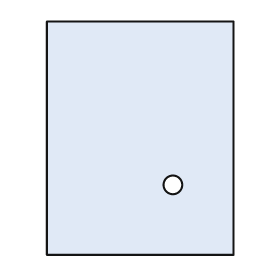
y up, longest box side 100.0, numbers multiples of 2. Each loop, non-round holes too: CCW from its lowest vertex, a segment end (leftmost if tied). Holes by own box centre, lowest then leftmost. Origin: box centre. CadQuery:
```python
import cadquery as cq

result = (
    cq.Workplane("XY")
    .moveTo(-40.0, -50.0)
    .lineTo(40.0, -50.0)
    .lineTo(40.0, 50.0)
    .lineTo(-40.0, 50.0)
    .close()
    .moveTo(14.0, -20.0)
    .circle(4.0)
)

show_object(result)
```